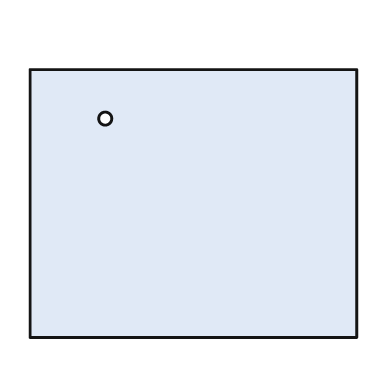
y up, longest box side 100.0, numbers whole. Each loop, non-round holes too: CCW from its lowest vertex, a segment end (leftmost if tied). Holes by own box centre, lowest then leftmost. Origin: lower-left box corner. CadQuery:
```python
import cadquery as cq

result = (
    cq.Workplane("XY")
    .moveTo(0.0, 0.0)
    .lineTo(100.0, 0.0)
    .lineTo(100.0, 82.0)
    .lineTo(0.0, 82.0)
    .close()
    .moveTo(23.0, 67.0)
    .circle(2.0)
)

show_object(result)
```